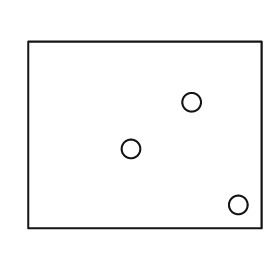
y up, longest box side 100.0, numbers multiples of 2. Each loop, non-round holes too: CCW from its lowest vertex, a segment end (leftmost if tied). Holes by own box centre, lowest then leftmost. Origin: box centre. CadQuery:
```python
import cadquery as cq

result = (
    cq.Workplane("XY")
    .moveTo(-50.0, -40.0)
    .lineTo(50.0, -40.0)
    .lineTo(50.0, 40.0)
    .lineTo(-50.0, 40.0)
    .close()
    .moveTo(40.0, -30.0)
    .circle(4.0)
    .moveTo(-6.0, -6.0)
    .circle(4.0)
    .moveTo(20.0, 14.0)
    .circle(4.0)
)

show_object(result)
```